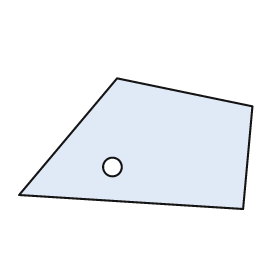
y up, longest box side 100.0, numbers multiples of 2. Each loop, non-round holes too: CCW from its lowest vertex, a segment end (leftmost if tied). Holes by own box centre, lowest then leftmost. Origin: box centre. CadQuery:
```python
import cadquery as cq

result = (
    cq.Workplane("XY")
    .moveTo(46.0, -28.0)
    .lineTo(50.0, 16.0)
    .lineTo(-8.0, 28.0)
    .lineTo(-50.0, -22.0)
    .close()
    .moveTo(-10.0, -10.0)
    .circle(4.0)
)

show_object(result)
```